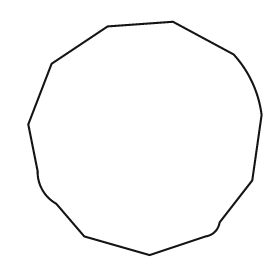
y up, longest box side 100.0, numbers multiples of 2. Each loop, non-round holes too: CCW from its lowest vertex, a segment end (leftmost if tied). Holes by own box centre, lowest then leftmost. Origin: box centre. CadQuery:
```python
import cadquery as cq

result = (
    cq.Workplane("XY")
    .moveTo(2.0, -50.0)
    .lineTo(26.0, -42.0)
    .threePointArc((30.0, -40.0), (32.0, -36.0))
    .lineTo(46.0, -18.0)
    .lineTo(50.0, 10.0)
    .threePointArc((46.0, 24.0), (38.0, 36.0))
    .lineTo(12.0, 50.0)
    .lineTo(-16.0, 48.0)
    .lineTo(-40.0, 32.0)
    .lineTo(-50.0, 6.0)
    .lineTo(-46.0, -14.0)
    .threePointArc((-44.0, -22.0), (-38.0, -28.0))
    .lineTo(-26.0, -42.0)
    .close()
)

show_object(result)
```